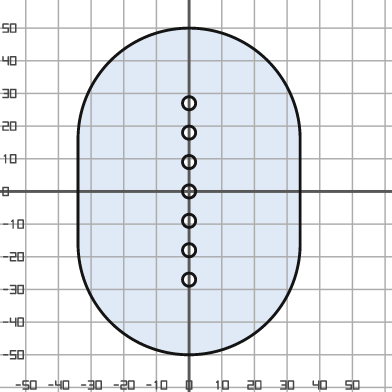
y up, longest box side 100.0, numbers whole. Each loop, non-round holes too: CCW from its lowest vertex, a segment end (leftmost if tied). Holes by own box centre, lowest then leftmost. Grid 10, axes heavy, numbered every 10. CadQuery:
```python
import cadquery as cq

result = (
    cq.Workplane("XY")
    .moveTo(-34.0, -16.0)
    .threePointArc((0.0, -50.0), (34.0, -16.0))
    .lineTo(34.0, 16.0)
    .threePointArc((0.0, 50.0), (-34.0, 16.0))
    .close()
    .moveTo(0.0, -27.0)
    .circle(2.0)
    .moveTo(0.0, -18.0)
    .circle(2.0)
    .moveTo(0.0, -9.0)
    .circle(2.0)
    .moveTo(0.0, 0.0)
    .circle(2.0)
    .moveTo(0.0, 9.0)
    .circle(2.0)
    .moveTo(0.0, 18.0)
    .circle(2.0)
    .moveTo(0.0, 27.0)
    .circle(2.0)
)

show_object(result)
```